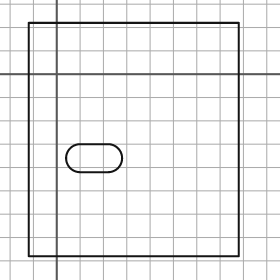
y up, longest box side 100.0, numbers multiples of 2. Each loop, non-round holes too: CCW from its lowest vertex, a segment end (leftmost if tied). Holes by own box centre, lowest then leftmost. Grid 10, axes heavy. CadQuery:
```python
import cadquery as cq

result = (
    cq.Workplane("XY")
    .moveTo(-12.0, -78.0)
    .lineTo(78.0, -78.0)
    .lineTo(78.0, 22.0)
    .lineTo(-12.0, 22.0)
    .close()
    .moveTo(10.0, -42.0)
    .lineTo(22.0, -42.0)
    .threePointArc((28.0, -36.0), (22.0, -30.0))
    .lineTo(10.0, -30.0)
    .threePointArc((4.0, -36.0), (10.0, -42.0))
    .close()
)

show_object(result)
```